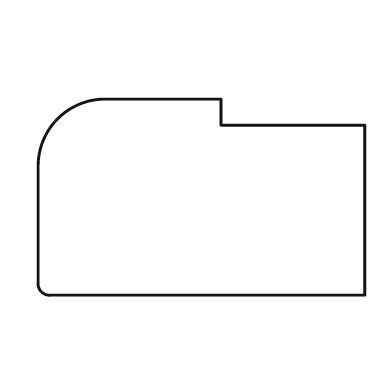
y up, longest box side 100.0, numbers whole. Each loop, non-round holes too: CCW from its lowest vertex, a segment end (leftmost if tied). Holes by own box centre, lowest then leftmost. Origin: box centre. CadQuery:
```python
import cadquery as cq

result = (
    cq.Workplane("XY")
    .moveTo(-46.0, -30.0)
    .lineTo(50.0, -30.0)
    .lineTo(50.0, 22.0)
    .lineTo(6.0, 22.0)
    .lineTo(6.0, 30.0)
    .lineTo(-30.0, 30.0)
    .threePointArc((-44.0, 24.0), (-50.0, 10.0))
    .lineTo(-50.0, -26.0)
    .threePointArc((-49.0, -29.0), (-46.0, -30.0))
    .close()
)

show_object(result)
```